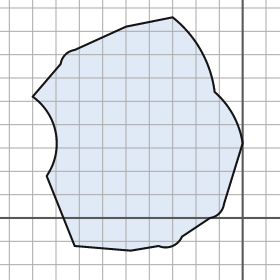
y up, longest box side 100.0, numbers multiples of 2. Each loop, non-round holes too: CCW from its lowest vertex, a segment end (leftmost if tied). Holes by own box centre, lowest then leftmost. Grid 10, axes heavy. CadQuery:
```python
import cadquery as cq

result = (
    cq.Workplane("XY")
    .moveTo(-48.0, -14.0)
    .lineTo(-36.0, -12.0)
    .threePointArc((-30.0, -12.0), (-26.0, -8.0))
    .lineTo(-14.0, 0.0)
    .threePointArc((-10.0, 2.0), (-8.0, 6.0))
    .lineTo(0.0, 32.0)
    .threePointArc((-4.0, 44.0), (-12.0, 54.0))
    .threePointArc((-18.0, 72.0), (-30.0, 86.0))
    .lineTo(-50.0, 82.0)
    .lineTo(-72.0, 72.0)
    .threePointArc((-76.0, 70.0), (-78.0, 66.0))
    .lineTo(-90.0, 52.0)
    .threePointArc((-80.0, 36.0), (-84.0, 18.0))
    .lineTo(-72.0, -12.0)
    .close()
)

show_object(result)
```